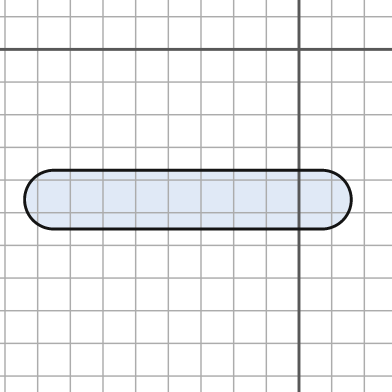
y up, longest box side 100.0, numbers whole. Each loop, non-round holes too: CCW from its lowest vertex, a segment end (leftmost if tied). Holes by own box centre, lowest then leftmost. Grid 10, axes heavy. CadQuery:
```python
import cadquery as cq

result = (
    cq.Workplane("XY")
    .moveTo(-75.0, -55.0)
    .lineTo(7.0, -55.0)
    .threePointArc((16.0, -46.0), (7.0, -37.0))
    .lineTo(-75.0, -37.0)
    .threePointArc((-84.0, -46.0), (-75.0, -55.0))
    .close()
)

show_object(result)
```